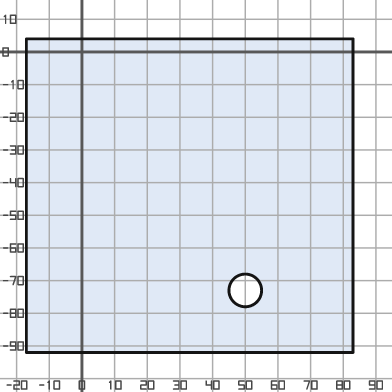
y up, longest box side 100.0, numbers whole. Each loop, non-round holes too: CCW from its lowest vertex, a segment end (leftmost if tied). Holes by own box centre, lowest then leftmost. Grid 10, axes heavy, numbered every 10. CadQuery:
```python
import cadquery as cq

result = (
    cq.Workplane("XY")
    .moveTo(-17.0, -92.0)
    .lineTo(83.0, -92.0)
    .lineTo(83.0, 4.0)
    .lineTo(-17.0, 4.0)
    .close()
    .moveTo(50.0, -73.0)
    .circle(5.0)
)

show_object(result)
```